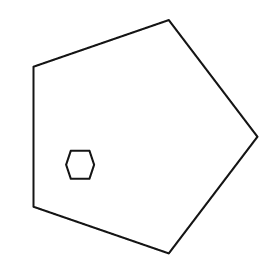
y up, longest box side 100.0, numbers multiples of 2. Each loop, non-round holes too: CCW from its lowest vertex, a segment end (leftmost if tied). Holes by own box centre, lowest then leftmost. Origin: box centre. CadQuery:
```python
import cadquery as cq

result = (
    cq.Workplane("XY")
    .moveTo(10.0, -50.0)
    .lineTo(48.0, 0.0)
    .lineTo(10.0, 50.0)
    .lineTo(-48.0, 30.0)
    .lineTo(-48.0, -30.0)
    .close()
    .moveTo(-32.0, -18.0)
    .lineTo(-24.0, -18.0)
    .lineTo(-22.0, -12.0)
    .lineTo(-24.0, -6.0)
    .lineTo(-32.0, -6.0)
    .lineTo(-34.0, -12.0)
    .close()
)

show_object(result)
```